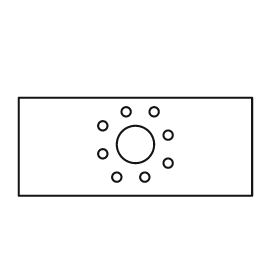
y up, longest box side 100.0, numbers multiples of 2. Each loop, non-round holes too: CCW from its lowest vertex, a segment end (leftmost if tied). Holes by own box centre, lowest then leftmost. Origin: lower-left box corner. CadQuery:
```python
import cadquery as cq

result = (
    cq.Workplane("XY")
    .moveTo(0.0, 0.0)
    .lineTo(100.0, 0.0)
    .lineTo(100.0, 42.0)
    .lineTo(0.0, 42.0)
    .close()
    .moveTo(42.0, 8.0)
    .circle(2.0)
    .moveTo(54.0, 8.0)
    .circle(2.0)
    .moveTo(64.0, 14.0)
    .circle(2.0)
    .moveTo(36.0, 18.0)
    .circle(2.0)
    .moveTo(50.0, 22.0)
    .circle(8.0)
    .moveTo(64.0, 26.0)
    .circle(2.0)
    .moveTo(36.0, 30.0)
    .circle(2.0)
    .moveTo(46.0, 36.0)
    .circle(2.0)
    .moveTo(58.0, 36.0)
    .circle(2.0)
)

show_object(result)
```